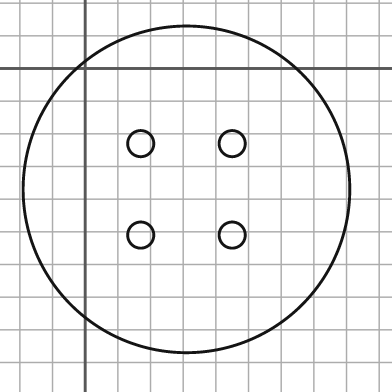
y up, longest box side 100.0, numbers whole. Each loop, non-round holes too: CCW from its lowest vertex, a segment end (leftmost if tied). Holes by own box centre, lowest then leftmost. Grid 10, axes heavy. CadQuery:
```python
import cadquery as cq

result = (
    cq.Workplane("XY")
    .moveTo(31.0, -37.0)
    .circle(50.0)
    .moveTo(17.0, -51.0)
    .circle(4.0)
    .moveTo(45.0, -51.0)
    .circle(4.0)
    .moveTo(17.0, -23.0)
    .circle(4.0)
    .moveTo(45.0, -23.0)
    .circle(4.0)
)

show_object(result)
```